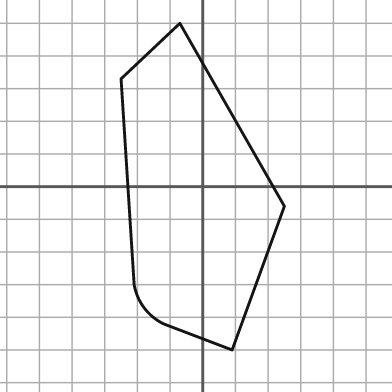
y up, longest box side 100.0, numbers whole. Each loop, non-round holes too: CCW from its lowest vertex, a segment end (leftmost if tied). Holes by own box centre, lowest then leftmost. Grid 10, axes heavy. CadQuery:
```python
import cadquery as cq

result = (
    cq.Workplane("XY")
    .moveTo(9.0, -50.0)
    .lineTo(25.0, -6.0)
    .lineTo(-7.0, 50.0)
    .lineTo(-25.0, 33.0)
    .lineTo(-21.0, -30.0)
    .threePointArc((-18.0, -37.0), (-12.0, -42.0))
    .close()
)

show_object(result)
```